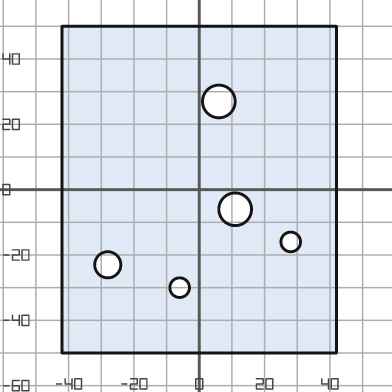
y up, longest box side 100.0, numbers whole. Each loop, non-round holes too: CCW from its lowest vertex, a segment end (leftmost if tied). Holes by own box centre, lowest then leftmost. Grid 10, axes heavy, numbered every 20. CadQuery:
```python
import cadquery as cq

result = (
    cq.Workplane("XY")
    .moveTo(-42.0, -50.0)
    .lineTo(42.0, -50.0)
    .lineTo(42.0, 50.0)
    .lineTo(-42.0, 50.0)
    .close()
    .moveTo(-6.0, -30.0)
    .circle(3.0)
    .moveTo(-28.0, -23.0)
    .circle(4.0)
    .moveTo(28.0, -16.0)
    .circle(3.0)
    .moveTo(11.0, -6.0)
    .circle(5.0)
    .moveTo(6.0, 27.0)
    .circle(5.0)
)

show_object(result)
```